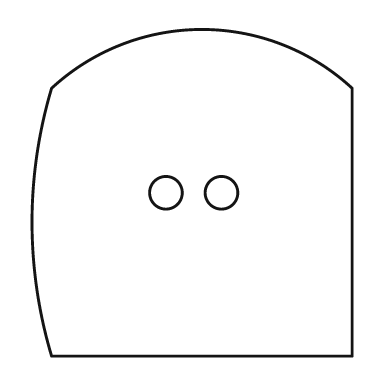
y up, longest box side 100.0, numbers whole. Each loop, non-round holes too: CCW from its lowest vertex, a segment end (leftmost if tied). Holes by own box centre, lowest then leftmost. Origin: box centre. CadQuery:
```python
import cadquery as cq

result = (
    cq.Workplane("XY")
    .moveTo(-43.0, -50.0)
    .lineTo(49.0, -50.0)
    .lineTo(49.0, 32.0)
    .threePointArc((3.0, 50.0), (-43.0, 32.0))
    .threePointArc((-49.0, -9.0), (-43.0, -50.0))
    .close()
    .moveTo(-8.0, 0.0)
    .circle(5.0)
    .moveTo(9.0, 0.0)
    .circle(5.0)
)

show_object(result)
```